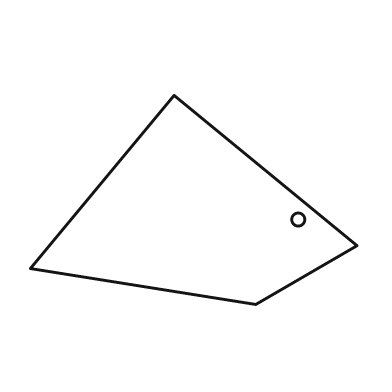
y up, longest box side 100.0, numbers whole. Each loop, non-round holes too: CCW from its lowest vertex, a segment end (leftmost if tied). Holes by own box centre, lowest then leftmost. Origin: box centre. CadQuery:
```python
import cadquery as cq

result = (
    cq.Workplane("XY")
    .moveTo(19.0, -32.0)
    .lineTo(50.0, -14.0)
    .lineTo(-6.0, 32.0)
    .lineTo(-50.0, -21.0)
    .close()
    .moveTo(32.0, -6.0)
    .circle(2.0)
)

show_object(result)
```